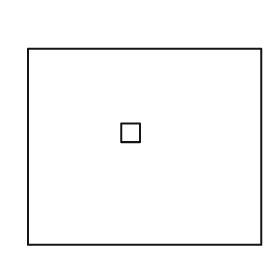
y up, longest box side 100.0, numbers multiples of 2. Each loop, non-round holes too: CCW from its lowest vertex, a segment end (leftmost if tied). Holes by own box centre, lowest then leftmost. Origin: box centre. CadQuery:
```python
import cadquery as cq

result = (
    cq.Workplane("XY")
    .moveTo(-50.0, -42.0)
    .lineTo(50.0, -42.0)
    .lineTo(50.0, 42.0)
    .lineTo(-50.0, 42.0)
    .close()
    .moveTo(-10.0, 2.0)
    .lineTo(-2.0, 2.0)
    .lineTo(-2.0, 10.0)
    .lineTo(-10.0, 10.0)
    .close()
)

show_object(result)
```